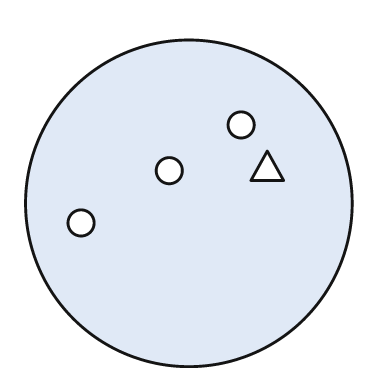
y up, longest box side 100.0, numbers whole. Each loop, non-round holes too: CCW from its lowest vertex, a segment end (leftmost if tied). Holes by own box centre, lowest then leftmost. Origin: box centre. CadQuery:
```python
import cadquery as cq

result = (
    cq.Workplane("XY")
    .moveTo(0.0, 0.0)
    .circle(50.0)
    .moveTo(-33.0, -6.0)
    .circle(4.0)
    .moveTo(-6.0, 10.0)
    .circle(4.0)
    .moveTo(19.0, 7.0)
    .lineTo(29.0, 7.0)
    .lineTo(24.0, 16.0)
    .close()
    .moveTo(16.0, 24.0)
    .circle(4.0)
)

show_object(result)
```